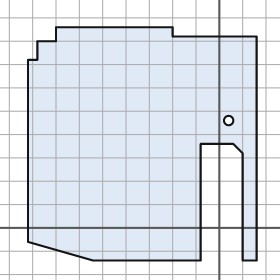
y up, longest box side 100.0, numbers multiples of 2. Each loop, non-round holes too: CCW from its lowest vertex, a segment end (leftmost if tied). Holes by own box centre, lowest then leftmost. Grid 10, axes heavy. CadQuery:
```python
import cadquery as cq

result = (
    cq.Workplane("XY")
    .moveTo(-54.0, -14.0)
    .lineTo(-8.0, -14.0)
    .lineTo(-8.0, 36.0)
    .lineTo(6.0, 36.0)
    .lineTo(10.0, 32.0)
    .lineTo(10.0, -14.0)
    .lineTo(16.0, -14.0)
    .lineTo(16.0, 82.0)
    .lineTo(-20.0, 82.0)
    .lineTo(-20.0, 86.0)
    .lineTo(-70.0, 86.0)
    .lineTo(-70.0, 80.0)
    .lineTo(-78.0, 80.0)
    .lineTo(-78.0, 72.0)
    .lineTo(-82.0, 72.0)
    .lineTo(-82.0, -6.0)
    .close()
    .moveTo(4.0, 46.0)
    .circle(2.0)
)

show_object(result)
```